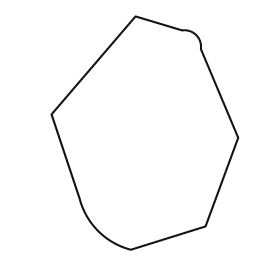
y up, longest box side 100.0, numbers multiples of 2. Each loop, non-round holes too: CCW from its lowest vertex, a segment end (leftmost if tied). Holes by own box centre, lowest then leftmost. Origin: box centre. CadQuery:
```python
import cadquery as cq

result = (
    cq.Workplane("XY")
    .moveTo(-6.0, -50.0)
    .lineTo(26.0, -40.0)
    .lineTo(40.0, -2.0)
    .lineTo(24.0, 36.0)
    .threePointArc((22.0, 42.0), (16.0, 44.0))
    .lineTo(-4.0, 50.0)
    .lineTo(-40.0, 8.0)
    .lineTo(-28.0, -28.0)
    .threePointArc((-20.0, -42.0), (-6.0, -50.0))
    .close()
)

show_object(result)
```